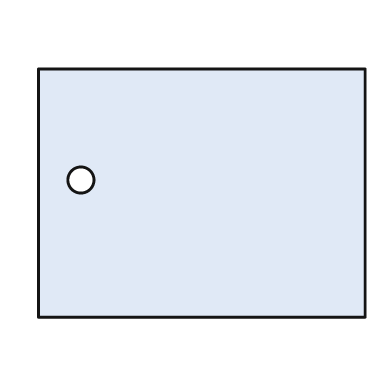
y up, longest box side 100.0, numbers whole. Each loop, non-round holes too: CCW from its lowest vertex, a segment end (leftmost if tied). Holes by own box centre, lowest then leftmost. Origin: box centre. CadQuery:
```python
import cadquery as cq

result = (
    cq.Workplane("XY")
    .moveTo(-50.0, -38.0)
    .lineTo(50.0, -38.0)
    .lineTo(50.0, 38.0)
    .lineTo(-50.0, 38.0)
    .close()
    .moveTo(-37.0, 4.0)
    .circle(4.0)
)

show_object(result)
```